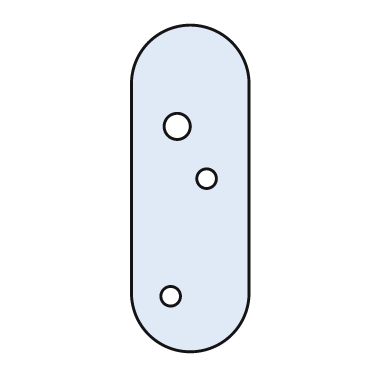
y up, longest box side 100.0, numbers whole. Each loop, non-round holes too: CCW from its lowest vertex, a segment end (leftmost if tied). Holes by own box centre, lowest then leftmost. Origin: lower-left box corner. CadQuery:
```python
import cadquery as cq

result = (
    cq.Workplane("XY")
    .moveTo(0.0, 18.0)
    .threePointArc((18.0, 0.0), (36.0, 18.0))
    .lineTo(36.0, 82.0)
    .threePointArc((18.0, 100.0), (0.0, 82.0))
    .close()
    .moveTo(12.0, 17.0)
    .circle(3.0)
    .moveTo(23.0, 53.0)
    .circle(3.0)
    .moveTo(14.0, 69.0)
    .circle(4.0)
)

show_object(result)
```